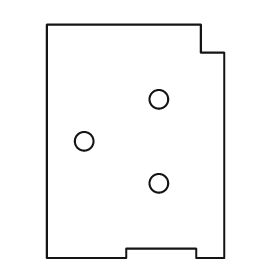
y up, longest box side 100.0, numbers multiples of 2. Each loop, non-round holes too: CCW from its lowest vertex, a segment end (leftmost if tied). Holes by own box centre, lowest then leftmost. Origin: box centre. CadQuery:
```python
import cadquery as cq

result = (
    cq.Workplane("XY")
    .moveTo(-38.0, -50.0)
    .lineTo(-4.0, -50.0)
    .lineTo(-4.0, -46.0)
    .lineTo(26.0, -46.0)
    .lineTo(26.0, -50.0)
    .lineTo(38.0, -50.0)
    .lineTo(38.0, 38.0)
    .lineTo(28.0, 38.0)
    .lineTo(28.0, 50.0)
    .lineTo(-38.0, 50.0)
    .close()
    .moveTo(10.0, -18.0)
    .circle(4.0)
    .moveTo(-22.0, 0.0)
    .circle(4.0)
    .moveTo(10.0, 18.0)
    .circle(4.0)
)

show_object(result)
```